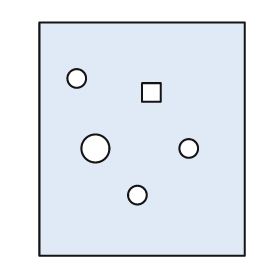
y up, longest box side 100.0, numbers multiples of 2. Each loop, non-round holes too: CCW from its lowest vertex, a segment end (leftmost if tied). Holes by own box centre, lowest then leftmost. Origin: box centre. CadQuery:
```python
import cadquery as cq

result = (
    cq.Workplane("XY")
    .moveTo(-44.0, -50.0)
    .lineTo(44.0, -50.0)
    .lineTo(44.0, 50.0)
    .lineTo(-44.0, 50.0)
    .close()
    .moveTo(-2.0, -24.0)
    .circle(4.0)
    .moveTo(-20.0, -4.0)
    .circle(6.0)
    .moveTo(20.0, -4.0)
    .circle(4.0)
    .moveTo(0.0, 16.0)
    .lineTo(8.0, 16.0)
    .lineTo(8.0, 24.0)
    .lineTo(0.0, 24.0)
    .close()
    .moveTo(-28.0, 26.0)
    .circle(4.0)
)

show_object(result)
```